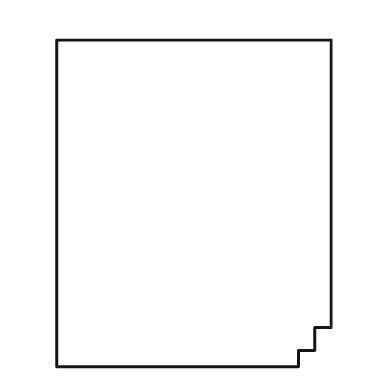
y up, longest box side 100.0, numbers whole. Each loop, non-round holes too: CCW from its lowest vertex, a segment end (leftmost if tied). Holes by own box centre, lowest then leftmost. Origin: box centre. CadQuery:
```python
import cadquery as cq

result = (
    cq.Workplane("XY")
    .moveTo(-42.0, -50.0)
    .lineTo(32.0, -50.0)
    .lineTo(32.0, -45.0)
    .lineTo(37.0, -45.0)
    .lineTo(37.0, -38.0)
    .lineTo(42.0, -38.0)
    .lineTo(42.0, 50.0)
    .lineTo(-42.0, 50.0)
    .close()
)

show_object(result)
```